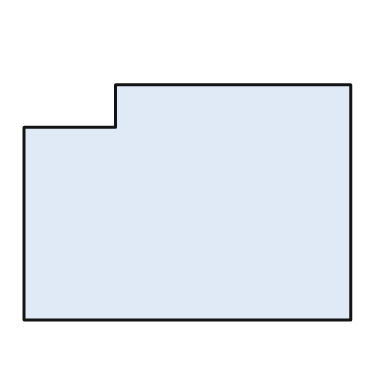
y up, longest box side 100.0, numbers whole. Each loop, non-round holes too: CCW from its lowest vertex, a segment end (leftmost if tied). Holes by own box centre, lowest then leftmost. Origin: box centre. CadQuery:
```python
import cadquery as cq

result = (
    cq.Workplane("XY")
    .moveTo(-50.0, -36.0)
    .lineTo(50.0, -36.0)
    .lineTo(50.0, 36.0)
    .lineTo(-22.0, 36.0)
    .lineTo(-22.0, 23.0)
    .lineTo(-50.0, 23.0)
    .close()
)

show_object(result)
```